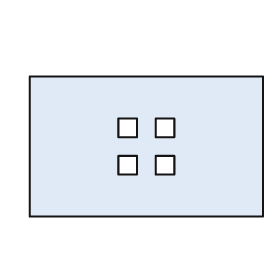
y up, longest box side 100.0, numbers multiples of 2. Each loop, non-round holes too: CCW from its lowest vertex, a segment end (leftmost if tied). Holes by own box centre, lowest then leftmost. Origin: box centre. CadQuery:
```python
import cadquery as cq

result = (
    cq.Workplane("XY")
    .moveTo(-50.0, -30.0)
    .lineTo(50.0, -30.0)
    .lineTo(50.0, 30.0)
    .lineTo(-50.0, 30.0)
    .close()
    .moveTo(-12.0, -12.0)
    .lineTo(-4.0, -12.0)
    .lineTo(-4.0, -4.0)
    .lineTo(-12.0, -4.0)
    .close()
    .moveTo(4.0, -12.0)
    .lineTo(12.0, -12.0)
    .lineTo(12.0, -4.0)
    .lineTo(4.0, -4.0)
    .close()
    .moveTo(-12.0, 4.0)
    .lineTo(-4.0, 4.0)
    .lineTo(-4.0, 12.0)
    .lineTo(-12.0, 12.0)
    .close()
    .moveTo(4.0, 4.0)
    .lineTo(12.0, 4.0)
    .lineTo(12.0, 12.0)
    .lineTo(4.0, 12.0)
    .close()
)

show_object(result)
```